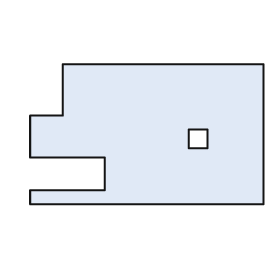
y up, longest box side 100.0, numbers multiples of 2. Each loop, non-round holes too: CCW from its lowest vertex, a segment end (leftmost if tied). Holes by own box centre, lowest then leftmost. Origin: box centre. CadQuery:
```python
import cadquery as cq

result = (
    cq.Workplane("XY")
    .moveTo(-50.0, -30.0)
    .lineTo(50.0, -30.0)
    .lineTo(50.0, 30.0)
    .lineTo(-36.0, 30.0)
    .lineTo(-36.0, 8.0)
    .lineTo(-50.0, 8.0)
    .lineTo(-50.0, -10.0)
    .lineTo(-18.0, -10.0)
    .lineTo(-18.0, -24.0)
    .lineTo(-50.0, -24.0)
    .close()
    .moveTo(18.0, -6.0)
    .lineTo(26.0, -6.0)
    .lineTo(26.0, 2.0)
    .lineTo(18.0, 2.0)
    .close()
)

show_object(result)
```